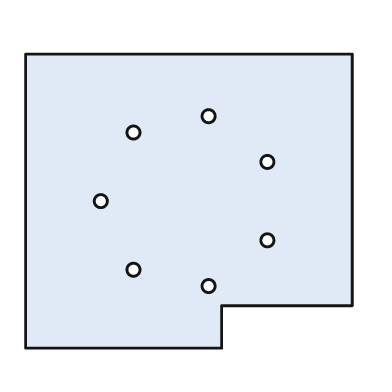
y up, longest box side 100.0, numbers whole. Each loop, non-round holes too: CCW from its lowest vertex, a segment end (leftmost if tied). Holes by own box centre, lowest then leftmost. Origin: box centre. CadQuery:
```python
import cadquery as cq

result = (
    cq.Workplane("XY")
    .moveTo(-50.0, -45.0)
    .lineTo(10.0, -45.0)
    .lineTo(10.0, -32.0)
    .lineTo(50.0, -32.0)
    .lineTo(50.0, 45.0)
    .lineTo(-50.0, 45.0)
    .close()
    .moveTo(6.0, -26.0)
    .circle(2.0)
    .moveTo(-17.0, -21.0)
    .circle(2.0)
    .moveTo(24.0, -12.0)
    .circle(2.0)
    .moveTo(-27.0, 0.0)
    .circle(2.0)
    .moveTo(24.0, 12.0)
    .circle(2.0)
    .moveTo(-17.0, 21.0)
    .circle(2.0)
    .moveTo(6.0, 26.0)
    .circle(2.0)
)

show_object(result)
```